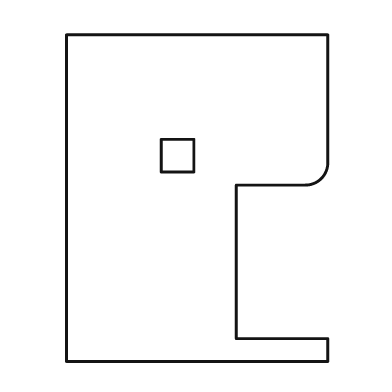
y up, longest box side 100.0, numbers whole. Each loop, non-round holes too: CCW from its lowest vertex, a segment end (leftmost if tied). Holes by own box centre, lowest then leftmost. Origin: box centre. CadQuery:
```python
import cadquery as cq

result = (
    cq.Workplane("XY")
    .moveTo(-40.0, -50.0)
    .lineTo(40.0, -50.0)
    .lineTo(40.0, -43.0)
    .lineTo(12.0, -43.0)
    .lineTo(12.0, 4.0)
    .lineTo(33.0, 4.0)
    .threePointArc((38.0, 6.0), (40.0, 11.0))
    .lineTo(40.0, 50.0)
    .lineTo(-40.0, 50.0)
    .close()
    .moveTo(-11.0, 8.0)
    .lineTo(-1.0, 8.0)
    .lineTo(-1.0, 18.0)
    .lineTo(-11.0, 18.0)
    .close()
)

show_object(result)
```